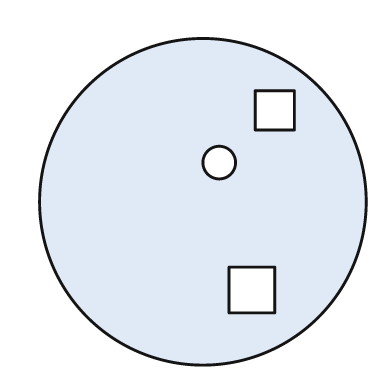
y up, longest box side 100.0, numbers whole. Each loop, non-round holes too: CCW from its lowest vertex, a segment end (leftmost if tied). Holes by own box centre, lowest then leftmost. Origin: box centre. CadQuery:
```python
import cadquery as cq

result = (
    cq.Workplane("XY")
    .moveTo(0.0, 0.0)
    .circle(50.0)
    .moveTo(8.0, -34.0)
    .lineTo(22.0, -34.0)
    .lineTo(22.0, -20.0)
    .lineTo(8.0, -20.0)
    .close()
    .moveTo(5.0, 12.0)
    .circle(5.0)
    .moveTo(16.0, 22.0)
    .lineTo(28.0, 22.0)
    .lineTo(28.0, 34.0)
    .lineTo(16.0, 34.0)
    .close()
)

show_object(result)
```